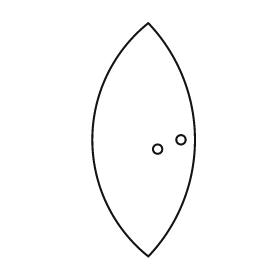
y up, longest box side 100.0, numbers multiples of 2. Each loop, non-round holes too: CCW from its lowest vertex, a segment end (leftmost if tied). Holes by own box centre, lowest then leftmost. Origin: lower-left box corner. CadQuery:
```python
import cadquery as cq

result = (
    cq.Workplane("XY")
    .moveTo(24.0, 0.0)
    .threePointArc((44.0, 50.0), (24.0, 100.0))
    .threePointArc((0.0, 50.0), (24.0, 0.0))
    .close()
    .moveTo(28.0, 46.0)
    .circle(2.0)
    .moveTo(38.0, 50.0)
    .circle(2.0)
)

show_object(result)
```